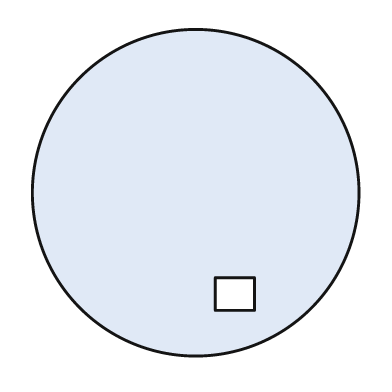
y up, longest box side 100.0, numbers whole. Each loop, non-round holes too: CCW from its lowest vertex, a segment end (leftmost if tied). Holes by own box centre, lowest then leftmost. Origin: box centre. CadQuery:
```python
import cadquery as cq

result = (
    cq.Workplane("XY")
    .moveTo(0.0, 0.0)
    .circle(50.0)
    .moveTo(6.0, -36.0)
    .lineTo(18.0, -36.0)
    .lineTo(18.0, -26.0)
    .lineTo(6.0, -26.0)
    .close()
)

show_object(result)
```